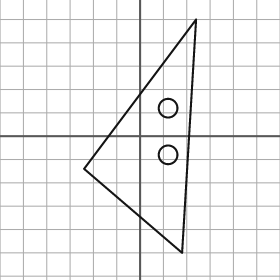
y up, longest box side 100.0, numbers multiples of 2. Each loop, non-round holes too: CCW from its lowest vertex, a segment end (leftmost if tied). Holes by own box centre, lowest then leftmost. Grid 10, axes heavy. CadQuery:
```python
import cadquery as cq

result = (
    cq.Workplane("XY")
    .moveTo(18.0, -50.0)
    .lineTo(24.0, 50.0)
    .lineTo(-24.0, -14.0)
    .close()
    .moveTo(12.0, -8.0)
    .circle(4.0)
    .moveTo(12.0, 12.0)
    .circle(4.0)
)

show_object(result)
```